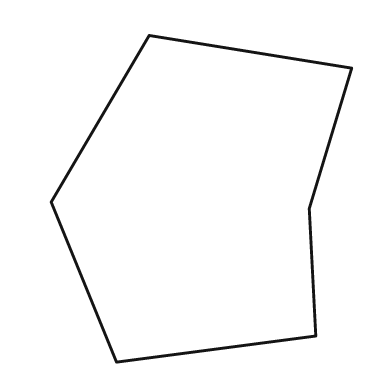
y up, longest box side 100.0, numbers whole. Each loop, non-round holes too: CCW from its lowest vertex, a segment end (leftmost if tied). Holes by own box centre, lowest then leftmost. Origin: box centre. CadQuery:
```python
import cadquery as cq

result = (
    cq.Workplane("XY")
    .moveTo(-26.0, -50.0)
    .lineTo(35.0, -42.0)
    .lineTo(33.0, -3.0)
    .lineTo(46.0, 40.0)
    .lineTo(-16.0, 50.0)
    .lineTo(-46.0, -1.0)
    .close()
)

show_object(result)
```